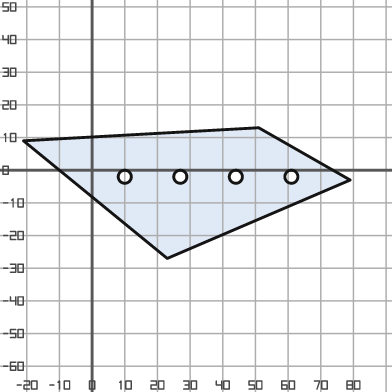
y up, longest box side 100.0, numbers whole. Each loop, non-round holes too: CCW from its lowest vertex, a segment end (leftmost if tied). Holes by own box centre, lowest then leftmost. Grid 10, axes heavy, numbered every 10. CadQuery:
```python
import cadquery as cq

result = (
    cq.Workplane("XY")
    .moveTo(23.0, -27.0)
    .lineTo(79.0, -3.0)
    .lineTo(51.0, 13.0)
    .lineTo(-21.0, 9.0)
    .close()
    .moveTo(10.0, -2.0)
    .circle(2.0)
    .moveTo(27.0, -2.0)
    .circle(2.0)
    .moveTo(44.0, -2.0)
    .circle(2.0)
    .moveTo(61.0, -2.0)
    .circle(2.0)
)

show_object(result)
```